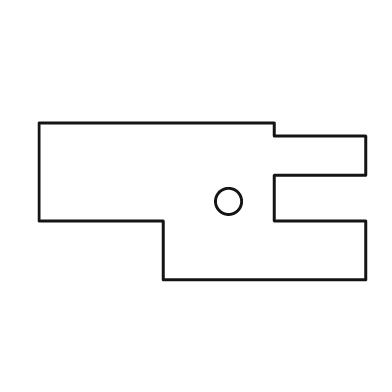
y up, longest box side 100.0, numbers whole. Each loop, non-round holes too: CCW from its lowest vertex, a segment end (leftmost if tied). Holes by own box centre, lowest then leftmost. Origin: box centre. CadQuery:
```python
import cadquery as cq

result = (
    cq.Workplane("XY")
    .moveTo(-12.0, -24.0)
    .lineTo(50.0, -24.0)
    .lineTo(50.0, -6.0)
    .lineTo(22.0, -6.0)
    .lineTo(22.0, 8.0)
    .lineTo(50.0, 8.0)
    .lineTo(50.0, 20.0)
    .lineTo(22.0, 20.0)
    .lineTo(22.0, 24.0)
    .lineTo(-50.0, 24.0)
    .lineTo(-50.0, -6.0)
    .lineTo(-12.0, -6.0)
    .close()
    .moveTo(8.0, 0.0)
    .circle(4.0)
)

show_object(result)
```